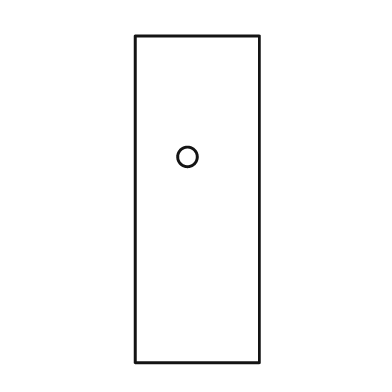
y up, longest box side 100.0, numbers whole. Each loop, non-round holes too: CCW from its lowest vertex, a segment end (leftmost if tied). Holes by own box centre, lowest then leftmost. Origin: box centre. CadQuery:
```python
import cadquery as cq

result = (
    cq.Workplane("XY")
    .moveTo(-19.0, -50.0)
    .lineTo(19.0, -50.0)
    .lineTo(19.0, 50.0)
    .lineTo(-19.0, 50.0)
    .close()
    .moveTo(-3.0, 13.0)
    .circle(3.0)
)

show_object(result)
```